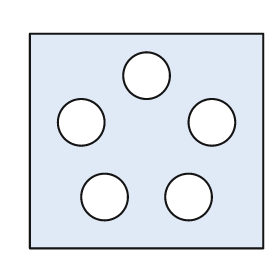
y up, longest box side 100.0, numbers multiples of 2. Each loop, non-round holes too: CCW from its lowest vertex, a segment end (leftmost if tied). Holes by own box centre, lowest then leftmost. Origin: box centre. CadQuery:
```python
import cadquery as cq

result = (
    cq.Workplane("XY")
    .moveTo(-50.0, -46.0)
    .lineTo(50.0, -46.0)
    .lineTo(50.0, 46.0)
    .lineTo(-50.0, 46.0)
    .close()
    .moveTo(-18.0, -24.0)
    .circle(10.0)
    .moveTo(18.0, -24.0)
    .circle(10.0)
    .moveTo(-28.0, 8.0)
    .circle(10.0)
    .moveTo(28.0, 8.0)
    .circle(10.0)
    .moveTo(0.0, 28.0)
    .circle(10.0)
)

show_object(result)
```